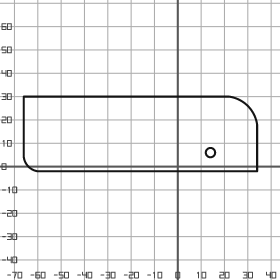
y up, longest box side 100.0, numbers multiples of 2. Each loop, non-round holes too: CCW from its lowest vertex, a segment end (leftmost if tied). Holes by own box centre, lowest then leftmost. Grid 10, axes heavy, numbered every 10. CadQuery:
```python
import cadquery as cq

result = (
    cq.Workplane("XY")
    .moveTo(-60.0, -2.0)
    .lineTo(34.0, -2.0)
    .lineTo(34.0, 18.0)
    .threePointArc((30.0, 26.0), (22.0, 30.0))
    .lineTo(-66.0, 30.0)
    .lineTo(-66.0, 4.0)
    .threePointArc((-64.0, 0.0), (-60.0, -2.0))
    .close()
    .moveTo(14.0, 6.0)
    .circle(2.0)
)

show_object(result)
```